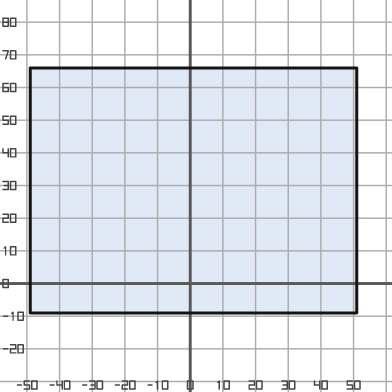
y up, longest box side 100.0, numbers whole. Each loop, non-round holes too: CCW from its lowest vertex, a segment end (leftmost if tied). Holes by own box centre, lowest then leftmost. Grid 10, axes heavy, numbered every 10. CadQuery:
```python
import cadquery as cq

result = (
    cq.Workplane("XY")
    .moveTo(-49.0, -9.0)
    .lineTo(51.0, -9.0)
    .lineTo(51.0, 66.0)
    .lineTo(-49.0, 66.0)
    .close()
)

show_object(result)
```